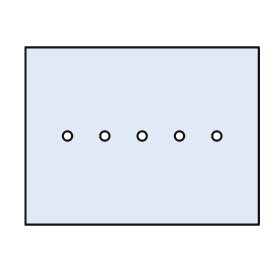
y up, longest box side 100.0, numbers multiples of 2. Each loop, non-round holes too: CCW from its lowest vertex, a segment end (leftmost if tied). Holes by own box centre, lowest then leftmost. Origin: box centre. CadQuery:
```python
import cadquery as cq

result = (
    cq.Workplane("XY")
    .moveTo(-50.0, -38.0)
    .lineTo(50.0, -38.0)
    .lineTo(50.0, 38.0)
    .lineTo(-50.0, 38.0)
    .close()
    .moveTo(-32.0, 0.0)
    .circle(2.0)
    .moveTo(-16.0, 0.0)
    .circle(2.0)
    .moveTo(0.0, 0.0)
    .circle(2.0)
    .moveTo(16.0, 0.0)
    .circle(2.0)
    .moveTo(32.0, 0.0)
    .circle(2.0)
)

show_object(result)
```